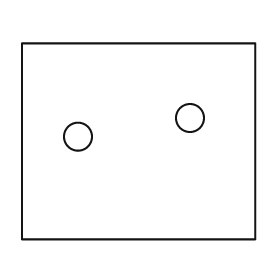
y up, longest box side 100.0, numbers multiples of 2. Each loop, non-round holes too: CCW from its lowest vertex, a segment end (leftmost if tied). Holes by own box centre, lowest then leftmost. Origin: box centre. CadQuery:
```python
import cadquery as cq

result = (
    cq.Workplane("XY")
    .moveTo(-50.0, -42.0)
    .lineTo(50.0, -42.0)
    .lineTo(50.0, 42.0)
    .lineTo(-50.0, 42.0)
    .close()
    .moveTo(-26.0, 2.0)
    .circle(6.0)
    .moveTo(22.0, 10.0)
    .circle(6.0)
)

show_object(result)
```